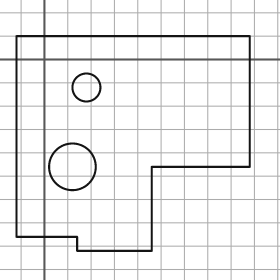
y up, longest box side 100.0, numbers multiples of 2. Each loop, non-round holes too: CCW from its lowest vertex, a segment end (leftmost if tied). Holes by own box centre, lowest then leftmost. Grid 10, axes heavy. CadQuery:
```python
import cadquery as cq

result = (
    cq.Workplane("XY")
    .moveTo(14.0, -82.0)
    .lineTo(46.0, -82.0)
    .lineTo(46.0, -46.0)
    .lineTo(88.0, -46.0)
    .lineTo(88.0, 10.0)
    .lineTo(-12.0, 10.0)
    .lineTo(-12.0, -76.0)
    .lineTo(14.0, -76.0)
    .close()
    .moveTo(12.0, -46.0)
    .circle(10.0)
    .moveTo(18.0, -12.0)
    .circle(6.0)
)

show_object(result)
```